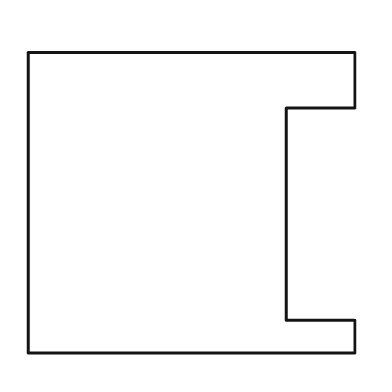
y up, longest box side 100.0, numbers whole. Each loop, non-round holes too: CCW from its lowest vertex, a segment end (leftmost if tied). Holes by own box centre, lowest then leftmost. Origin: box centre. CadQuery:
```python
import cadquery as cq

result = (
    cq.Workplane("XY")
    .moveTo(-50.0, -46.0)
    .lineTo(50.0, -46.0)
    .lineTo(50.0, -36.0)
    .lineTo(29.0, -36.0)
    .lineTo(29.0, 29.0)
    .lineTo(50.0, 29.0)
    .lineTo(50.0, 46.0)
    .lineTo(-50.0, 46.0)
    .close()
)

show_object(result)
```